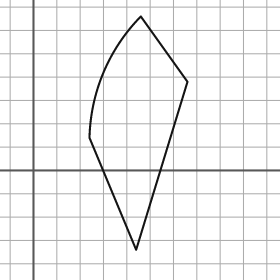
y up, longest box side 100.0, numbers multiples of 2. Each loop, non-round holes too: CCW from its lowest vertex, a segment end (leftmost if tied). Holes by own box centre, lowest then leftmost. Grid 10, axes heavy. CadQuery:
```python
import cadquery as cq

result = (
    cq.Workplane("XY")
    .moveTo(44.0, -34.0)
    .lineTo(66.0, 38.0)
    .lineTo(46.0, 66.0)
    .threePointArc((30.0, 42.0), (24.0, 14.0))
    .close()
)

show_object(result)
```